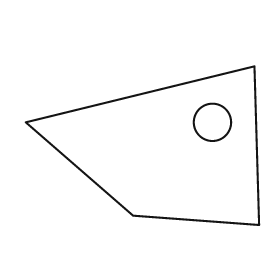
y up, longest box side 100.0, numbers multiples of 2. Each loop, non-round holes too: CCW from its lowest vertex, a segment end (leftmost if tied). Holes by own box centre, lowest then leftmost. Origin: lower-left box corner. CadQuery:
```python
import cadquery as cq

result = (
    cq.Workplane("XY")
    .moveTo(100.0, 0.0)
    .lineTo(98.0, 68.0)
    .lineTo(0.0, 44.0)
    .lineTo(46.0, 4.0)
    .close()
    .moveTo(80.0, 44.0)
    .circle(8.0)
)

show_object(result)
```